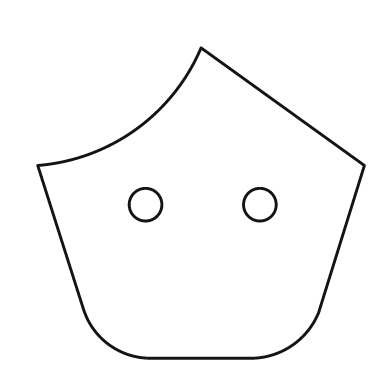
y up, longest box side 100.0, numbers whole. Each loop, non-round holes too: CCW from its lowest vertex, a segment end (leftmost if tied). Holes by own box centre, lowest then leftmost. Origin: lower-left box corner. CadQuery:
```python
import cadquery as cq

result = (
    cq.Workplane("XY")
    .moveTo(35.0, 0.0)
    .lineTo(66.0, 0.0)
    .threePointArc((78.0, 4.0), (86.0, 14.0))
    .lineTo(100.0, 59.0)
    .lineTo(50.0, 95.0)
    .threePointArc((30.0, 70.0), (0.0, 59.0))
    .lineTo(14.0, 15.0)
    .threePointArc((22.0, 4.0), (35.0, 0.0))
    .close()
    .moveTo(33.0, 47.0)
    .circle(5.0)
    .moveTo(68.0, 47.0)
    .circle(5.0)
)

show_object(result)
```